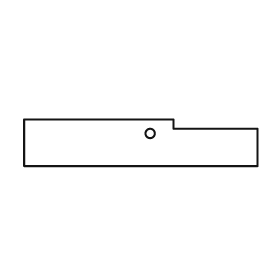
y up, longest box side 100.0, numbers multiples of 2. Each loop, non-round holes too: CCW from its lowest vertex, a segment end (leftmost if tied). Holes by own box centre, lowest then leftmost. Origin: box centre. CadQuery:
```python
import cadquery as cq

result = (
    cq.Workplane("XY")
    .moveTo(-50.0, -10.0)
    .lineTo(50.0, -10.0)
    .lineTo(50.0, 6.0)
    .lineTo(14.0, 6.0)
    .lineTo(14.0, 10.0)
    .lineTo(-50.0, 10.0)
    .close()
    .moveTo(4.0, 4.0)
    .circle(2.0)
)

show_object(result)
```